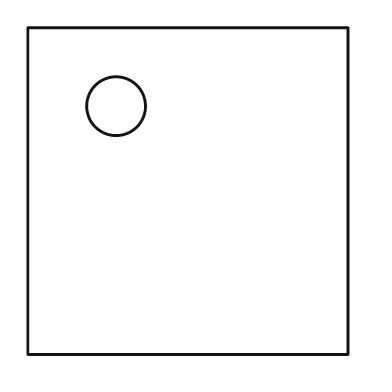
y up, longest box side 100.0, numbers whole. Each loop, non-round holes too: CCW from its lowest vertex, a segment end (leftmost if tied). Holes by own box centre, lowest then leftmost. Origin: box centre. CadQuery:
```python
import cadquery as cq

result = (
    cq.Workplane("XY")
    .moveTo(-49.0, -50.0)
    .lineTo(49.0, -50.0)
    .lineTo(49.0, 50.0)
    .lineTo(-49.0, 50.0)
    .close()
    .moveTo(-22.0, 26.0)
    .circle(9.0)
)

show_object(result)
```